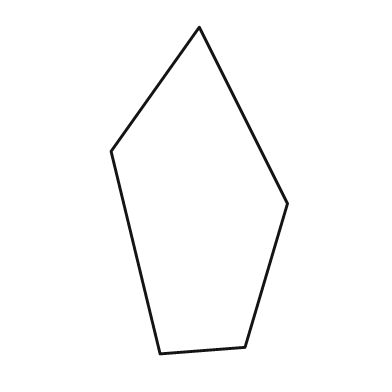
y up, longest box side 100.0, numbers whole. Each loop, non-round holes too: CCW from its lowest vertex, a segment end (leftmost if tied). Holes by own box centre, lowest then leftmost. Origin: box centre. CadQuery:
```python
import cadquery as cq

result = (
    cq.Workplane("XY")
    .moveTo(-12.0, -50.0)
    .lineTo(14.0, -48.0)
    .lineTo(27.0, -4.0)
    .lineTo(0.0, 50.0)
    .lineTo(-27.0, 12.0)
    .close()
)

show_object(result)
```